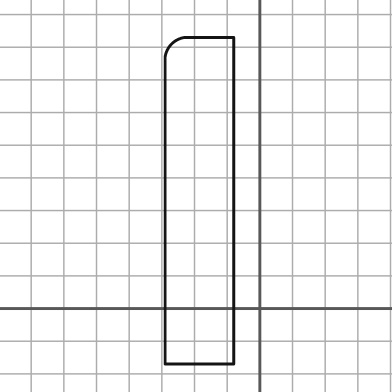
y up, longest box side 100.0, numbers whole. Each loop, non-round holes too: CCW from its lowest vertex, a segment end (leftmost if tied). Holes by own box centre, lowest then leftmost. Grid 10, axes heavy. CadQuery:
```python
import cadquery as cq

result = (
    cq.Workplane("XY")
    .moveTo(-29.0, -17.0)
    .lineTo(-8.0, -17.0)
    .lineTo(-8.0, 83.0)
    .lineTo(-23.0, 83.0)
    .threePointArc((-27.0, 81.0), (-29.0, 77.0))
    .close()
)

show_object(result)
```